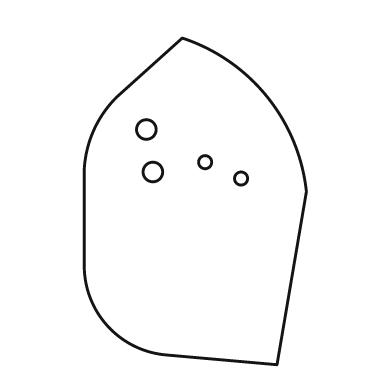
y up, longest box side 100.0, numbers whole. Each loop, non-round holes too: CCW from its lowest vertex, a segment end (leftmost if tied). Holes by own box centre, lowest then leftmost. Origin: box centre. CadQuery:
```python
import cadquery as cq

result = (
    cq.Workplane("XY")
    .moveTo(25.0, -50.0)
    .lineTo(34.0, 3.0)
    .threePointArc((22.0, 32.0), (-4.0, 50.0))
    .lineTo(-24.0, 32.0)
    .threePointArc((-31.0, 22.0), (-34.0, 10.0))
    .lineTo(-34.0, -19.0)
    .threePointArc((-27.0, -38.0), (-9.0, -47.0))
    .close()
    .moveTo(14.0, 7.0)
    .circle(2.0)
    .moveTo(-13.0, 9.0)
    .circle(3.0)
    .moveTo(3.0, 12.0)
    .circle(2.0)
    .moveTo(-15.0, 22.0)
    .circle(3.0)
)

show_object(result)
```